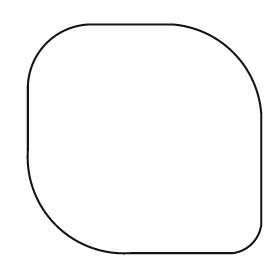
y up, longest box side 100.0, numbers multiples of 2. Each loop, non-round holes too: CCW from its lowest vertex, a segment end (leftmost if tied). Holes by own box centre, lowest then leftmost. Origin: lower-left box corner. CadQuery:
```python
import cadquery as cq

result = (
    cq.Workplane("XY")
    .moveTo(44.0, 0.0)
    .lineTo(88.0, 0.0)
    .threePointArc((96.0, 4.0), (100.0, 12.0))
    .lineTo(100.0, 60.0)
    .threePointArc((88.0, 86.0), (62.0, 98.0))
    .lineTo(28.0, 98.0)
    .threePointArc((8.0, 90.0), (0.0, 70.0))
    .lineTo(0.0, 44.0)
    .threePointArc((12.0, 12.0), (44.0, 0.0))
    .close()
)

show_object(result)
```